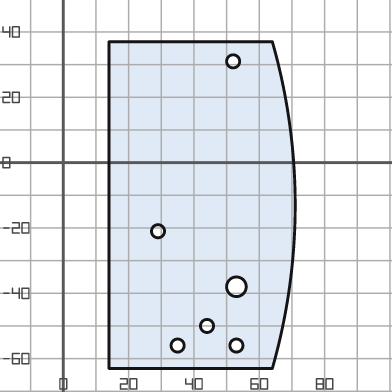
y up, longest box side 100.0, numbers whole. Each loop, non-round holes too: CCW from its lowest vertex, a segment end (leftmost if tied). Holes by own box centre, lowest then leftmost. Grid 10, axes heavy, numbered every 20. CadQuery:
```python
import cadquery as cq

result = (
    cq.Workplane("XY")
    .moveTo(14.0, -63.0)
    .lineTo(64.0, -63.0)
    .threePointArc((71.0, -13.0), (64.0, 37.0))
    .lineTo(14.0, 37.0)
    .close()
    .moveTo(35.0, -56.0)
    .circle(2.0)
    .moveTo(53.0, -56.0)
    .circle(2.0)
    .moveTo(44.0, -50.0)
    .circle(2.0)
    .moveTo(53.0, -38.0)
    .circle(3.0)
    .moveTo(29.0, -21.0)
    .circle(2.0)
    .moveTo(52.0, 31.0)
    .circle(2.0)
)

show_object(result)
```